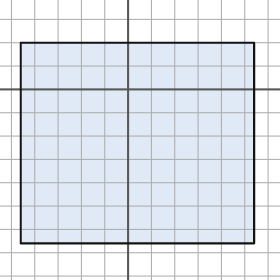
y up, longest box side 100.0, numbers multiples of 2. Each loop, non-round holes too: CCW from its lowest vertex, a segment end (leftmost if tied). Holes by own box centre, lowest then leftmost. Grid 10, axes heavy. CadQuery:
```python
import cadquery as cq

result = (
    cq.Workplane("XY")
    .moveTo(-46.0, -66.0)
    .lineTo(54.0, -66.0)
    .lineTo(54.0, 20.0)
    .lineTo(-46.0, 20.0)
    .close()
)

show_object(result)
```